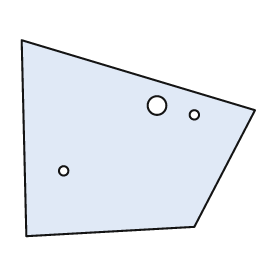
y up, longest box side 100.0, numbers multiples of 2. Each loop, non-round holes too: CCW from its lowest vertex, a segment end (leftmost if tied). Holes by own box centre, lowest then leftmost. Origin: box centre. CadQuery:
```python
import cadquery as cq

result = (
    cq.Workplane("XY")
    .moveTo(-48.0, -42.0)
    .lineTo(24.0, -38.0)
    .lineTo(50.0, 12.0)
    .lineTo(-50.0, 42.0)
    .close()
    .moveTo(-32.0, -14.0)
    .circle(2.0)
    .moveTo(24.0, 10.0)
    .circle(2.0)
    .moveTo(8.0, 14.0)
    .circle(4.0)
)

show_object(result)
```